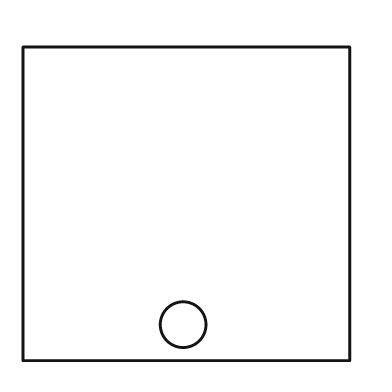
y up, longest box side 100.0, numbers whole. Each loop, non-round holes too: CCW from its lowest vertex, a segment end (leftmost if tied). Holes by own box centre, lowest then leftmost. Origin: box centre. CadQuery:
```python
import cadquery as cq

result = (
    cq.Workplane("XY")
    .moveTo(-50.0, -48.0)
    .lineTo(50.0, -48.0)
    .lineTo(50.0, 48.0)
    .lineTo(-50.0, 48.0)
    .close()
    .moveTo(-1.0, -37.0)
    .circle(7.0)
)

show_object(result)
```